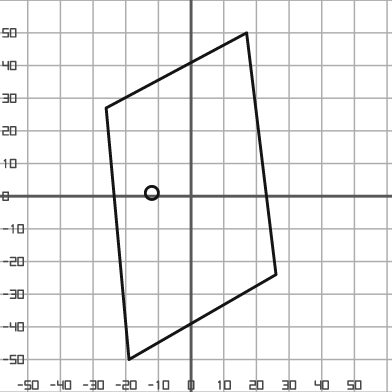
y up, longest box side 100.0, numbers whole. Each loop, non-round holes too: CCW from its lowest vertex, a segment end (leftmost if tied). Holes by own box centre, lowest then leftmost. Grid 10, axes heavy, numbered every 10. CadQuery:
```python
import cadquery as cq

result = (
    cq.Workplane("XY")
    .moveTo(-19.0, -50.0)
    .lineTo(26.0, -24.0)
    .lineTo(17.0, 50.0)
    .lineTo(-26.0, 27.0)
    .close()
    .moveTo(-12.0, 1.0)
    .circle(2.0)
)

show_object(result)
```